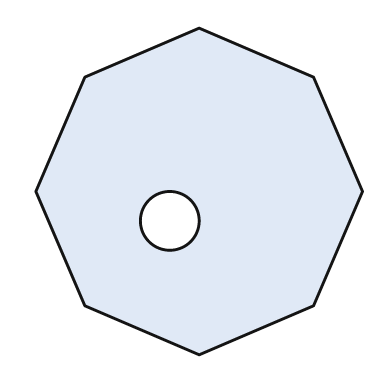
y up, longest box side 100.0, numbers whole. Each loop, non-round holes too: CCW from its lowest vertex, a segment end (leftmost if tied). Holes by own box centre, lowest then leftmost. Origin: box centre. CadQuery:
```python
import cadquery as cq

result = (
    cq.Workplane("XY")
    .moveTo(0.0, -50.0)
    .lineTo(35.0, -35.0)
    .lineTo(50.0, 0.0)
    .lineTo(35.0, 35.0)
    .lineTo(0.0, 50.0)
    .lineTo(-35.0, 35.0)
    .lineTo(-50.0, 0.0)
    .lineTo(-35.0, -35.0)
    .close()
    .moveTo(-9.0, -9.0)
    .circle(9.0)
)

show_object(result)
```